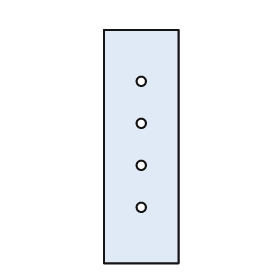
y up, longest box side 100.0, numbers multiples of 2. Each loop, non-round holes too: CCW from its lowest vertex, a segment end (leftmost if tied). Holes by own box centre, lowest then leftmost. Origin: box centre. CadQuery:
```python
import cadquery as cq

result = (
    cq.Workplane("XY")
    .moveTo(-16.0, -50.0)
    .lineTo(16.0, -50.0)
    .lineTo(16.0, 50.0)
    .lineTo(-16.0, 50.0)
    .close()
    .moveTo(0.0, -26.0)
    .circle(2.0)
    .moveTo(0.0, -8.0)
    .circle(2.0)
    .moveTo(0.0, 10.0)
    .circle(2.0)
    .moveTo(0.0, 28.0)
    .circle(2.0)
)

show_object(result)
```